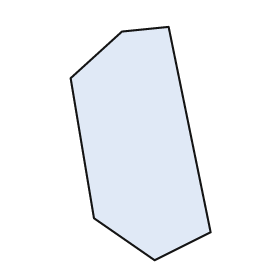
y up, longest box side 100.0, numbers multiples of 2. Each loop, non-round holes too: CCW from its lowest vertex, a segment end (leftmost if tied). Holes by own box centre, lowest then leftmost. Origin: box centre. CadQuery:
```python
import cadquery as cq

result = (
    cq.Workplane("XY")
    .moveTo(6.0, -50.0)
    .lineTo(30.0, -38.0)
    .lineTo(12.0, 50.0)
    .lineTo(-8.0, 48.0)
    .lineTo(-30.0, 28.0)
    .lineTo(-20.0, -32.0)
    .close()
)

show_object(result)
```